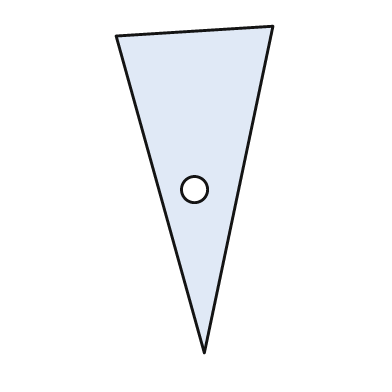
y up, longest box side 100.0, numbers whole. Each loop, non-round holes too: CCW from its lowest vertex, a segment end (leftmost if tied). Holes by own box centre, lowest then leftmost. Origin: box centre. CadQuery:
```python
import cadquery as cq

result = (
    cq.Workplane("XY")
    .moveTo(3.0, -50.0)
    .lineTo(24.0, 50.0)
    .lineTo(-24.0, 47.0)
    .close()
    .moveTo(0.0, 0.0)
    .circle(4.0)
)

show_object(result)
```